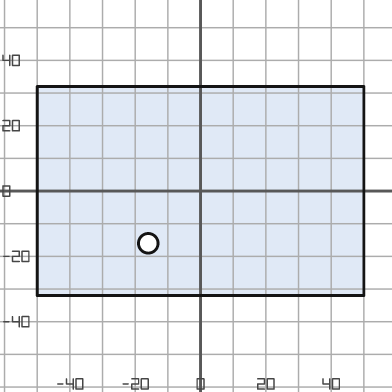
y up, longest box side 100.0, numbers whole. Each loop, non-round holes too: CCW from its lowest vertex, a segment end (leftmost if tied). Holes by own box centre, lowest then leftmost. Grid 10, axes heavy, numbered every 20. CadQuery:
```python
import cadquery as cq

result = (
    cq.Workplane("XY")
    .moveTo(-50.0, -32.0)
    .lineTo(50.0, -32.0)
    .lineTo(50.0, 32.0)
    .lineTo(-50.0, 32.0)
    .close()
    .moveTo(-16.0, -16.0)
    .circle(3.0)
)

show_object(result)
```